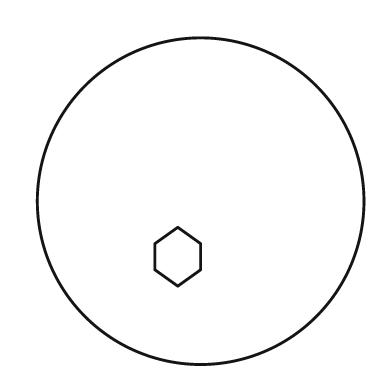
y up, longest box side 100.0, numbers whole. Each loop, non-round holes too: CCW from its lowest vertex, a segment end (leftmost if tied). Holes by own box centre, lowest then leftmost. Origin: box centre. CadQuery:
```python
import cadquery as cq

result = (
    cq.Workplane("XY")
    .moveTo(0.0, 0.0)
    .circle(50.0)
    .moveTo(-7.0, -26.0)
    .lineTo(0.0, -21.0)
    .lineTo(0.0, -13.0)
    .lineTo(-7.0, -8.0)
    .lineTo(-14.0, -13.0)
    .lineTo(-14.0, -21.0)
    .close()
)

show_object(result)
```